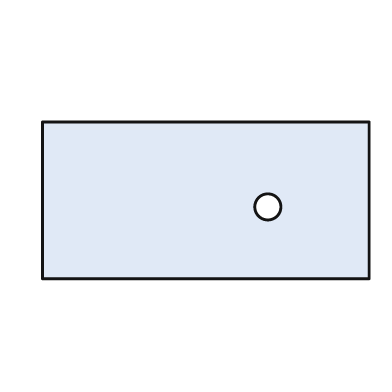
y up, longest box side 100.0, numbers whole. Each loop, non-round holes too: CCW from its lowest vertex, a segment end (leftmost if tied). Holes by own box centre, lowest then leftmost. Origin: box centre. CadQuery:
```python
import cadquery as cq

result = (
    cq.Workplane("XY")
    .moveTo(-50.0, -24.0)
    .lineTo(50.0, -24.0)
    .lineTo(50.0, 24.0)
    .lineTo(-50.0, 24.0)
    .close()
    .moveTo(19.0, -2.0)
    .circle(4.0)
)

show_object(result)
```